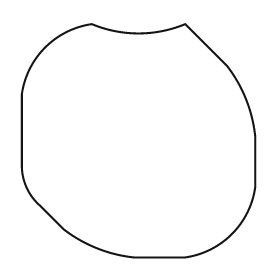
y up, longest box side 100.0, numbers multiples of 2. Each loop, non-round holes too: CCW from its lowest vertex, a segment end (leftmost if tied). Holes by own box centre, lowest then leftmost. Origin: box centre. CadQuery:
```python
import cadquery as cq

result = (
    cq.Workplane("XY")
    .moveTo(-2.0, -50.0)
    .lineTo(20.0, -50.0)
    .threePointArc((40.0, -40.0), (50.0, -20.0))
    .lineTo(50.0, 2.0)
    .threePointArc((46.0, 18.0), (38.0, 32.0))
    .lineTo(20.0, 50.0)
    .threePointArc((0.0, 46.0), (-20.0, 50.0))
    .threePointArc((-40.0, 40.0), (-50.0, 20.0))
    .lineTo(-50.0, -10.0)
    .threePointArc((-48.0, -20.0), (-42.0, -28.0))
    .lineTo(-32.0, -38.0)
    .threePointArc((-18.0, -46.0), (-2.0, -50.0))
    .close()
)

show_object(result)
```